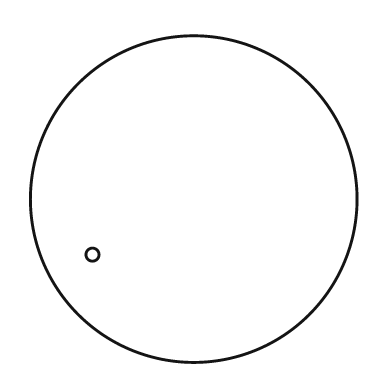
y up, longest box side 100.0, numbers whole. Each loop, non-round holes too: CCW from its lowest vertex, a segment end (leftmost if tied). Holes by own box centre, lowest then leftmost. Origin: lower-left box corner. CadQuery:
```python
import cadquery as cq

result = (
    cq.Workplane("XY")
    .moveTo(50.0, 50.0)
    .circle(50.0)
    .moveTo(19.0, 33.0)
    .circle(2.0)
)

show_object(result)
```